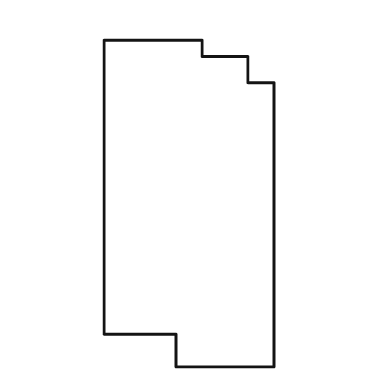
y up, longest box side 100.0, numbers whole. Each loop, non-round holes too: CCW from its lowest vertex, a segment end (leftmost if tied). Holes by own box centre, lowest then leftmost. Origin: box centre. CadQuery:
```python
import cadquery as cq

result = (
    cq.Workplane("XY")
    .moveTo(-4.0, -50.0)
    .lineTo(26.0, -50.0)
    .lineTo(26.0, 37.0)
    .lineTo(18.0, 37.0)
    .lineTo(18.0, 45.0)
    .lineTo(4.0, 45.0)
    .lineTo(4.0, 50.0)
    .lineTo(-26.0, 50.0)
    .lineTo(-26.0, -40.0)
    .lineTo(-4.0, -40.0)
    .close()
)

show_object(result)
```